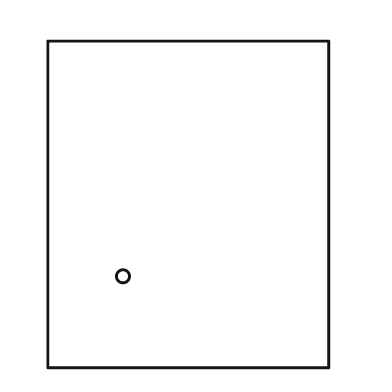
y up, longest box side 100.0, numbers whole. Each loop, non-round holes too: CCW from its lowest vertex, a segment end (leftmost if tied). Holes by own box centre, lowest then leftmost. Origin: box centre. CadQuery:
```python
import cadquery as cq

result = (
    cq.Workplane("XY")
    .moveTo(-43.0, -50.0)
    .lineTo(43.0, -50.0)
    .lineTo(43.0, 50.0)
    .lineTo(-43.0, 50.0)
    .close()
    .moveTo(-20.0, -22.0)
    .circle(2.0)
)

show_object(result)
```